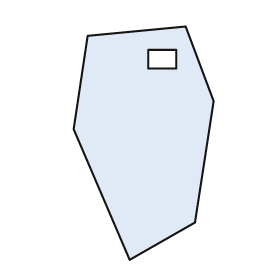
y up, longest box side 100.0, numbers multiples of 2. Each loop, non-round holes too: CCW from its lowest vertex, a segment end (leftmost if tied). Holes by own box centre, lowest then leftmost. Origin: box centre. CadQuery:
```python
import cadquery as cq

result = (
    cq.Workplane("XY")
    .moveTo(-6.0, -50.0)
    .lineTo(22.0, -34.0)
    .lineTo(30.0, 18.0)
    .lineTo(18.0, 50.0)
    .lineTo(-24.0, 46.0)
    .lineTo(-30.0, 6.0)
    .close()
    .moveTo(2.0, 32.0)
    .lineTo(14.0, 32.0)
    .lineTo(14.0, 40.0)
    .lineTo(2.0, 40.0)
    .close()
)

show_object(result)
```